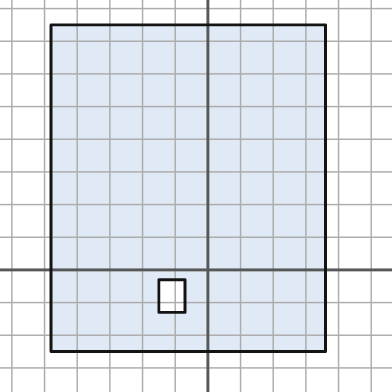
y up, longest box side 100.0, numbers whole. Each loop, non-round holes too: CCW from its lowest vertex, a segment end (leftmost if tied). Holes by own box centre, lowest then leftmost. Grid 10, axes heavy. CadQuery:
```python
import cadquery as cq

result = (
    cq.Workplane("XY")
    .moveTo(-48.0, -25.0)
    .lineTo(36.0, -25.0)
    .lineTo(36.0, 75.0)
    .lineTo(-48.0, 75.0)
    .close()
    .moveTo(-15.0, -13.0)
    .lineTo(-7.0, -13.0)
    .lineTo(-7.0, -3.0)
    .lineTo(-15.0, -3.0)
    .close()
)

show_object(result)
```